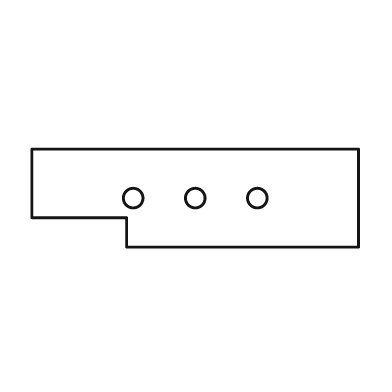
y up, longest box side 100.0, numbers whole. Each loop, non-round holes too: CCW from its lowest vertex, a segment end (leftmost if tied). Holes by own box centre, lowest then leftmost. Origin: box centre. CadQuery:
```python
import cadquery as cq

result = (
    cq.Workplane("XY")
    .moveTo(-21.0, -15.0)
    .lineTo(50.0, -15.0)
    .lineTo(50.0, 15.0)
    .lineTo(-50.0, 15.0)
    .lineTo(-50.0, -6.0)
    .lineTo(-21.0, -6.0)
    .close()
    .moveTo(-19.0, 0.0)
    .circle(3.0)
    .moveTo(0.0, 0.0)
    .circle(3.0)
    .moveTo(19.0, 0.0)
    .circle(3.0)
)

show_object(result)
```